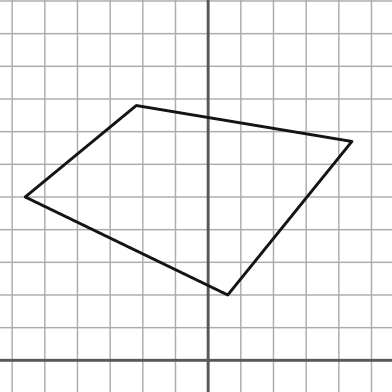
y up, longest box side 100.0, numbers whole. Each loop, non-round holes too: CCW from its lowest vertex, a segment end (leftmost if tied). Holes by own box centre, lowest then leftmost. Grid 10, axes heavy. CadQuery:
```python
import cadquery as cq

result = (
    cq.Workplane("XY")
    .moveTo(6.0, 20.0)
    .lineTo(44.0, 67.0)
    .lineTo(-22.0, 78.0)
    .lineTo(-56.0, 50.0)
    .close()
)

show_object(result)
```